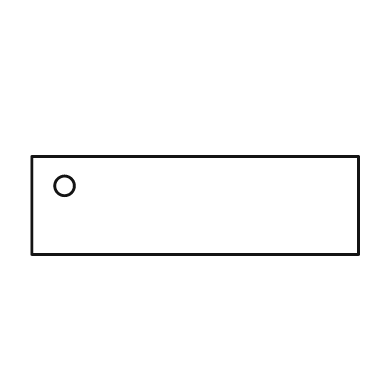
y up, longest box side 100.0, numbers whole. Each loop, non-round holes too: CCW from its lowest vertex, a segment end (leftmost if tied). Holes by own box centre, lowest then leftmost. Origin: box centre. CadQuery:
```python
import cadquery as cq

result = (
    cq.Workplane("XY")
    .moveTo(-50.0, -15.0)
    .lineTo(50.0, -15.0)
    .lineTo(50.0, 15.0)
    .lineTo(-50.0, 15.0)
    .close()
    .moveTo(-40.0, 6.0)
    .circle(3.0)
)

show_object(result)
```